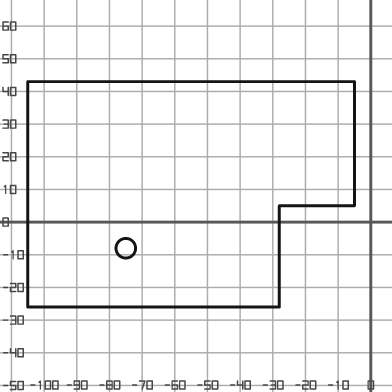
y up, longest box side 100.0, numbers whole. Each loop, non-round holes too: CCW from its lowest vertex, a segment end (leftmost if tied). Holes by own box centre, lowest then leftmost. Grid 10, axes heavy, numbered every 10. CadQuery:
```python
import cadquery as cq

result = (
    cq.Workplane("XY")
    .moveTo(-105.0, -26.0)
    .lineTo(-28.0, -26.0)
    .lineTo(-28.0, 5.0)
    .lineTo(-5.0, 5.0)
    .lineTo(-5.0, 43.0)
    .lineTo(-105.0, 43.0)
    .close()
    .moveTo(-75.0, -8.0)
    .circle(3.0)
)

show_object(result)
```